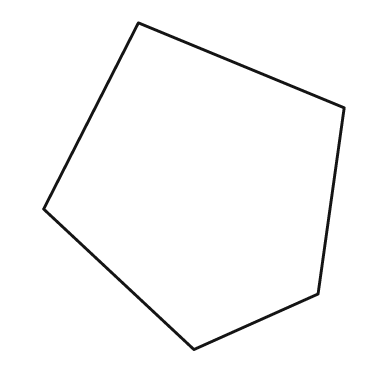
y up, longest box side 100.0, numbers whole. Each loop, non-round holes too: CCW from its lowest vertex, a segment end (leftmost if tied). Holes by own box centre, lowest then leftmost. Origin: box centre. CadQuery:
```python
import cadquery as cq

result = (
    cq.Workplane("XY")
    .moveTo(0.0, -50.0)
    .lineTo(38.0, -33.0)
    .lineTo(46.0, 24.0)
    .lineTo(-17.0, 50.0)
    .lineTo(-46.0, -7.0)
    .close()
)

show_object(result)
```